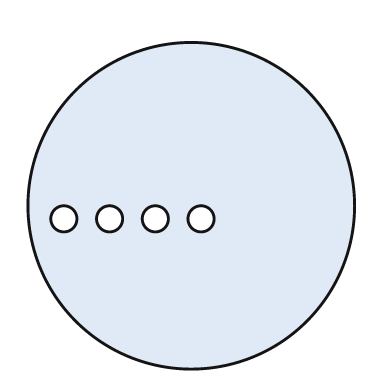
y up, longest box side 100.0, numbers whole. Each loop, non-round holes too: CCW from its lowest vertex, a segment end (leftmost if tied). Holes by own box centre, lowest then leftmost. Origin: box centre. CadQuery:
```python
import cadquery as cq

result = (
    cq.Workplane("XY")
    .moveTo(0.0, 0.0)
    .circle(50.0)
    .moveTo(-39.0, -4.0)
    .circle(4.0)
    .moveTo(-25.0, -4.0)
    .circle(4.0)
    .moveTo(-11.0, -4.0)
    .circle(4.0)
    .moveTo(3.0, -4.0)
    .circle(4.0)
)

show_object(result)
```